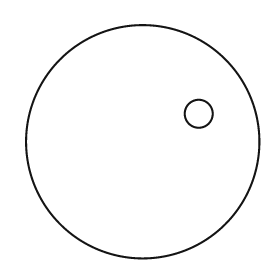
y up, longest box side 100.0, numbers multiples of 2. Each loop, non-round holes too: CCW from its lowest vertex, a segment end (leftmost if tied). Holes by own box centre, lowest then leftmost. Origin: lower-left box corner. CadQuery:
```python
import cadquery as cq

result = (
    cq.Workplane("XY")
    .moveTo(50.0, 50.0)
    .circle(50.0)
    .moveTo(74.0, 62.0)
    .circle(6.0)
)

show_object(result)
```